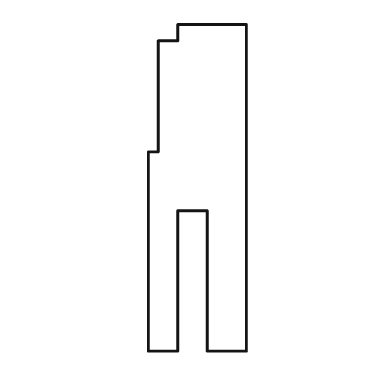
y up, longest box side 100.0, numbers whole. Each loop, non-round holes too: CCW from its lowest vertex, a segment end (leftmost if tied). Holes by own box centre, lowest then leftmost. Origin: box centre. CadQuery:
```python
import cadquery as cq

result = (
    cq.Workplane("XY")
    .moveTo(-15.0, -50.0)
    .lineTo(-6.0, -50.0)
    .lineTo(-6.0, -7.0)
    .lineTo(3.0, -7.0)
    .lineTo(3.0, -50.0)
    .lineTo(15.0, -50.0)
    .lineTo(15.0, 50.0)
    .lineTo(-6.0, 50.0)
    .lineTo(-6.0, 45.0)
    .lineTo(-12.0, 45.0)
    .lineTo(-12.0, 11.0)
    .lineTo(-15.0, 11.0)
    .close()
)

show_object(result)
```